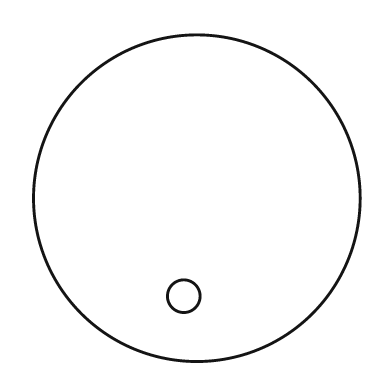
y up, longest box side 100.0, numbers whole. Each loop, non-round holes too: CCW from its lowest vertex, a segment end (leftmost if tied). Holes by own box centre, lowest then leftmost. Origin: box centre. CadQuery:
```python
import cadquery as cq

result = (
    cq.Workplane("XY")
    .moveTo(0.0, 0.0)
    .circle(50.0)
    .moveTo(-4.0, -30.0)
    .circle(5.0)
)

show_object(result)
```